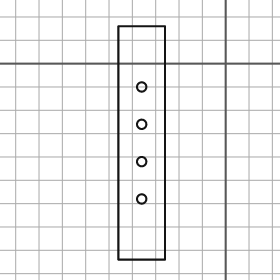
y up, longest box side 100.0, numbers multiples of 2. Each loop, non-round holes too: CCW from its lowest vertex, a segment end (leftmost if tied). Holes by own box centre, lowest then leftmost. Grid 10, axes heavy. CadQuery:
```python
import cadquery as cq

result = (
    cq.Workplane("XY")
    .moveTo(-46.0, -84.0)
    .lineTo(-26.0, -84.0)
    .lineTo(-26.0, 16.0)
    .lineTo(-46.0, 16.0)
    .close()
    .moveTo(-36.0, -58.0)
    .circle(2.0)
    .moveTo(-36.0, -42.0)
    .circle(2.0)
    .moveTo(-36.0, -26.0)
    .circle(2.0)
    .moveTo(-36.0, -10.0)
    .circle(2.0)
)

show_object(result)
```